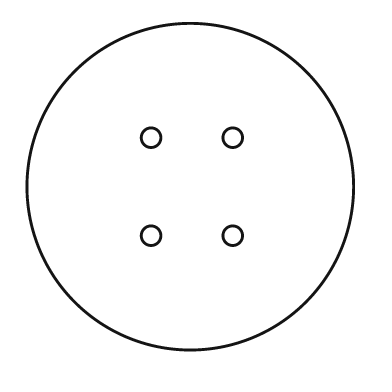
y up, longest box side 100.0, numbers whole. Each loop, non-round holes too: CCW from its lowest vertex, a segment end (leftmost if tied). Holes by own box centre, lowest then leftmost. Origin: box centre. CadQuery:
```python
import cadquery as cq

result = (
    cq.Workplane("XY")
    .moveTo(0.0, 0.0)
    .circle(50.0)
    .moveTo(-12.0, -15.0)
    .circle(3.0)
    .moveTo(13.0, -15.0)
    .circle(3.0)
    .moveTo(-12.0, 15.0)
    .circle(3.0)
    .moveTo(13.0, 15.0)
    .circle(3.0)
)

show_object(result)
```